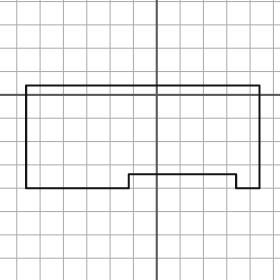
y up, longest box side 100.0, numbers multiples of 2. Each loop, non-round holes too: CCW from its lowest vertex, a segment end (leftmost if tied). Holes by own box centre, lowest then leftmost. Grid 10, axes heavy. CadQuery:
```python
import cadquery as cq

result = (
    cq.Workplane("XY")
    .moveTo(-56.0, -40.0)
    .lineTo(-12.0, -40.0)
    .lineTo(-12.0, -34.0)
    .lineTo(34.0, -34.0)
    .lineTo(34.0, -40.0)
    .lineTo(44.0, -40.0)
    .lineTo(44.0, 4.0)
    .lineTo(-56.0, 4.0)
    .close()
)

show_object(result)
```